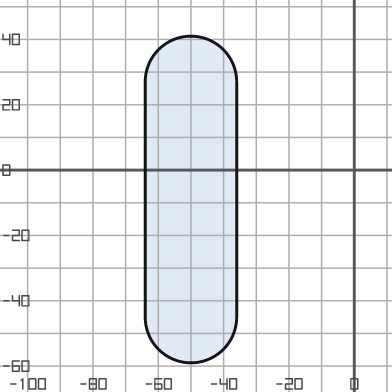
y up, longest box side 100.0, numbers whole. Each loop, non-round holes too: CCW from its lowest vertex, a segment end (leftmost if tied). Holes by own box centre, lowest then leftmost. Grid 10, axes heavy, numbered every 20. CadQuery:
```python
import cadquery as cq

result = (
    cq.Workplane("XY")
    .moveTo(-64.0, -45.0)
    .threePointArc((-50.0, -59.0), (-36.0, -45.0))
    .lineTo(-36.0, 27.0)
    .threePointArc((-50.0, 41.0), (-64.0, 27.0))
    .close()
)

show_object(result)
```